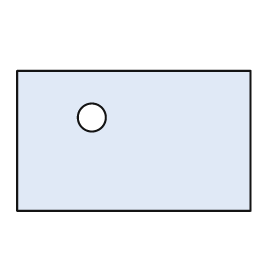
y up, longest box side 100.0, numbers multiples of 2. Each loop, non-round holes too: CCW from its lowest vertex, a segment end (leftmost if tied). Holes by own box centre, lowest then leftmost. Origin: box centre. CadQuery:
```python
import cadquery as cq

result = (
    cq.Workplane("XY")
    .moveTo(-50.0, -30.0)
    .lineTo(50.0, -30.0)
    .lineTo(50.0, 30.0)
    .lineTo(-50.0, 30.0)
    .close()
    .moveTo(-18.0, 10.0)
    .circle(6.0)
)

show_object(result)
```